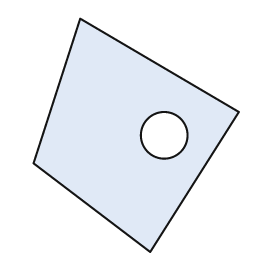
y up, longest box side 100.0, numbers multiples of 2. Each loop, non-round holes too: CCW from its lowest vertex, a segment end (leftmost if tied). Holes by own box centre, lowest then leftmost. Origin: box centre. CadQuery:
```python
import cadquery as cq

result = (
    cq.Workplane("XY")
    .moveTo(6.0, -50.0)
    .lineTo(44.0, 10.0)
    .lineTo(-24.0, 50.0)
    .lineTo(-44.0, -12.0)
    .close()
    .moveTo(12.0, 0.0)
    .circle(10.0)
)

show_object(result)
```